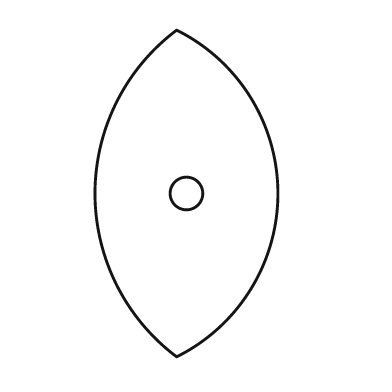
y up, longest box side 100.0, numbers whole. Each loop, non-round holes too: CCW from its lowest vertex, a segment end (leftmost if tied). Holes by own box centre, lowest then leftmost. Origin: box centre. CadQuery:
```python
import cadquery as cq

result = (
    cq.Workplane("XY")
    .moveTo(-3.0, -50.0)
    .threePointArc((28.0, 0.0), (-3.0, 50.0))
    .threePointArc((-28.0, 0.0), (-3.0, -50.0))
    .close()
    .moveTo(0.0, 0.0)
    .circle(5.0)
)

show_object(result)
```